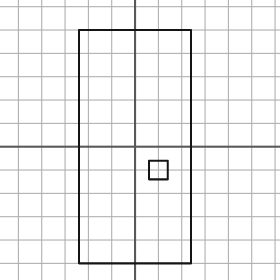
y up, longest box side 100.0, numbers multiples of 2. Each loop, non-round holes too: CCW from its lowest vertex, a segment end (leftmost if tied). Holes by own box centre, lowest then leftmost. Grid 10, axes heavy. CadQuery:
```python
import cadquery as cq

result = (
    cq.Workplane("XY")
    .moveTo(-24.0, -50.0)
    .lineTo(24.0, -50.0)
    .lineTo(24.0, 50.0)
    .lineTo(-24.0, 50.0)
    .close()
    .moveTo(6.0, -14.0)
    .lineTo(14.0, -14.0)
    .lineTo(14.0, -6.0)
    .lineTo(6.0, -6.0)
    .close()
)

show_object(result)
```